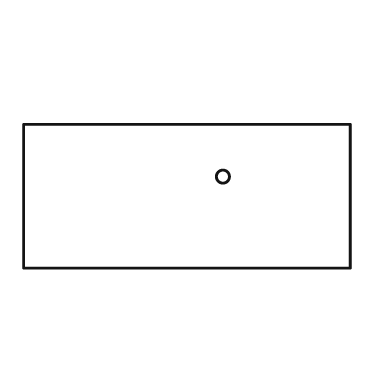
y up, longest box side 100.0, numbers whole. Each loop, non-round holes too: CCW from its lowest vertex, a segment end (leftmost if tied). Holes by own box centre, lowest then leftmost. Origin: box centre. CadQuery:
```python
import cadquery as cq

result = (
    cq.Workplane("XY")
    .moveTo(-50.0, -22.0)
    .lineTo(50.0, -22.0)
    .lineTo(50.0, 22.0)
    .lineTo(-50.0, 22.0)
    .close()
    .moveTo(11.0, 6.0)
    .circle(2.0)
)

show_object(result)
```